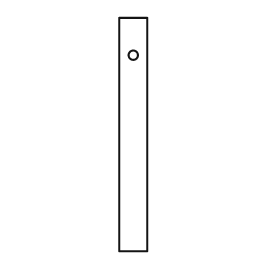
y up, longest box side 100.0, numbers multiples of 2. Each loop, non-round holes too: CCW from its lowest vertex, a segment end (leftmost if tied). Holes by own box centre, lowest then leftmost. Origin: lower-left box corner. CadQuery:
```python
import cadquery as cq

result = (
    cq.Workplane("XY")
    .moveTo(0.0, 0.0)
    .lineTo(12.0, 0.0)
    .lineTo(12.0, 100.0)
    .lineTo(0.0, 100.0)
    .close()
    .moveTo(6.0, 84.0)
    .circle(2.0)
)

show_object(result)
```